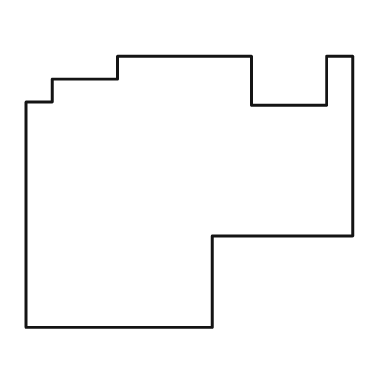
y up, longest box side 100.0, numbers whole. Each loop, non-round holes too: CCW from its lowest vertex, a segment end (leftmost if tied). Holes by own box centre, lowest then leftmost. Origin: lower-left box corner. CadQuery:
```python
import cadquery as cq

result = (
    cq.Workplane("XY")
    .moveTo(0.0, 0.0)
    .lineTo(57.0, 0.0)
    .lineTo(57.0, 28.0)
    .lineTo(100.0, 28.0)
    .lineTo(100.0, 83.0)
    .lineTo(92.0, 83.0)
    .lineTo(92.0, 68.0)
    .lineTo(69.0, 68.0)
    .lineTo(69.0, 83.0)
    .lineTo(28.0, 83.0)
    .lineTo(28.0, 76.0)
    .lineTo(8.0, 76.0)
    .lineTo(8.0, 69.0)
    .lineTo(0.0, 69.0)
    .close()
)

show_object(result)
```